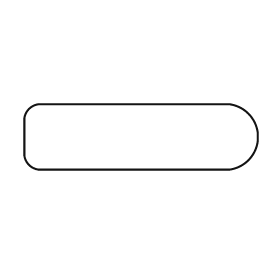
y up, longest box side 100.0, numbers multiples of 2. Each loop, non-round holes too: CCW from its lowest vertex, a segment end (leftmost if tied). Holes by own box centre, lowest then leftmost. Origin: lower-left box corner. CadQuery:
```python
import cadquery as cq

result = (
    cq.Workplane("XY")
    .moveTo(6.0, 0.0)
    .lineTo(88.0, 0.0)
    .threePointArc((96.0, 4.0), (100.0, 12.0))
    .lineTo(100.0, 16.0)
    .threePointArc((96.0, 24.0), (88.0, 28.0))
    .lineTo(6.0, 28.0)
    .threePointArc((2.0, 26.0), (0.0, 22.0))
    .lineTo(0.0, 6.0)
    .threePointArc((2.0, 2.0), (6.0, 0.0))
    .close()
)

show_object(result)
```